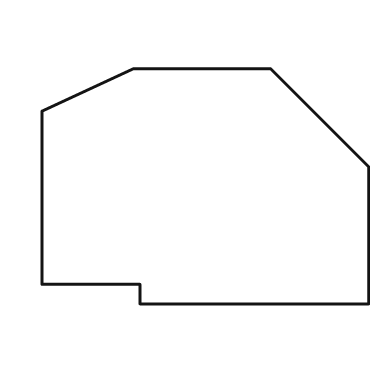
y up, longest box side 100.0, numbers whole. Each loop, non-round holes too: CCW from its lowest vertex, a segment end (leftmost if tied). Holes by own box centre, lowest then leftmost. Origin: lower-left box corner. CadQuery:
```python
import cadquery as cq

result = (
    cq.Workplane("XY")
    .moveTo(30.0, 0.0)
    .lineTo(100.0, 0.0)
    .lineTo(100.0, 42.0)
    .lineTo(70.0, 72.0)
    .lineTo(28.0, 72.0)
    .lineTo(0.0, 59.0)
    .lineTo(0.0, 6.0)
    .lineTo(30.0, 6.0)
    .close()
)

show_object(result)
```